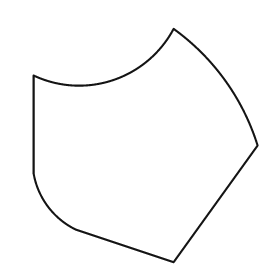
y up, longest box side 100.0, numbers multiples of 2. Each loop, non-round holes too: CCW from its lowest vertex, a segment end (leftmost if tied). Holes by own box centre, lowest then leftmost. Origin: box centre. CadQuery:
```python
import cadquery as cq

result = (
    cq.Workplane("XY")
    .moveTo(12.0, -50.0)
    .lineTo(48.0, 0.0)
    .threePointArc((34.0, 28.0), (12.0, 50.0))
    .threePointArc((-14.0, 28.0), (-48.0, 30.0))
    .lineTo(-48.0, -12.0)
    .threePointArc((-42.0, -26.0), (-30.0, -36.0))
    .close()
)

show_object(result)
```